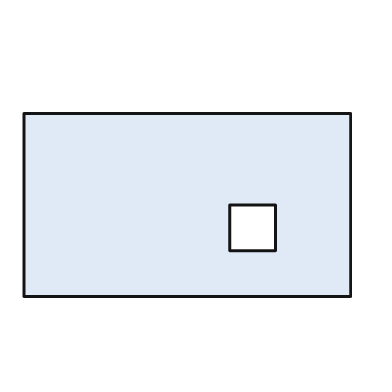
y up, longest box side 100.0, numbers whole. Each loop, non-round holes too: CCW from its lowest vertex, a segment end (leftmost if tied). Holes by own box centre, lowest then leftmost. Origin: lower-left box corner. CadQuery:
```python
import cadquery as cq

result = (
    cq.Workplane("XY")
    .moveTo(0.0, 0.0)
    .lineTo(100.0, 0.0)
    .lineTo(100.0, 56.0)
    .lineTo(0.0, 56.0)
    .close()
    .moveTo(63.0, 14.0)
    .lineTo(77.0, 14.0)
    .lineTo(77.0, 28.0)
    .lineTo(63.0, 28.0)
    .close()
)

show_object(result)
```